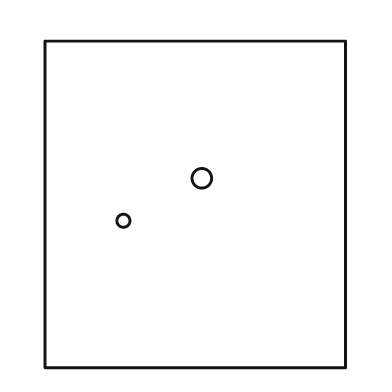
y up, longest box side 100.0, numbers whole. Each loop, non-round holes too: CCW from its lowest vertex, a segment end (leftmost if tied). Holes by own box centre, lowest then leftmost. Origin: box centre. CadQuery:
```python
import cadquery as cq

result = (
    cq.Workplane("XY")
    .moveTo(-46.0, -50.0)
    .lineTo(46.0, -50.0)
    .lineTo(46.0, 50.0)
    .lineTo(-46.0, 50.0)
    .close()
    .moveTo(-22.0, -5.0)
    .circle(2.0)
    .moveTo(2.0, 8.0)
    .circle(3.0)
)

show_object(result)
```